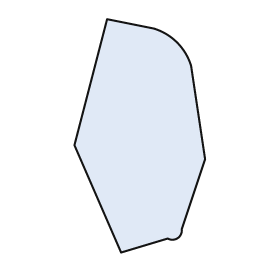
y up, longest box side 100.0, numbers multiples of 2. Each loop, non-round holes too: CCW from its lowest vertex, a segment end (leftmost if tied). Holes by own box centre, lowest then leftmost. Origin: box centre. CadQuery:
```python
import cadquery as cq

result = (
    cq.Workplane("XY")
    .moveTo(-8.0, -50.0)
    .lineTo(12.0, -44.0)
    .threePointArc((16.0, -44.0), (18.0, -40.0))
    .lineTo(28.0, -10.0)
    .lineTo(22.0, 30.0)
    .threePointArc((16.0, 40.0), (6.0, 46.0))
    .lineTo(-14.0, 50.0)
    .lineTo(-28.0, -4.0)
    .close()
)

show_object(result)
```